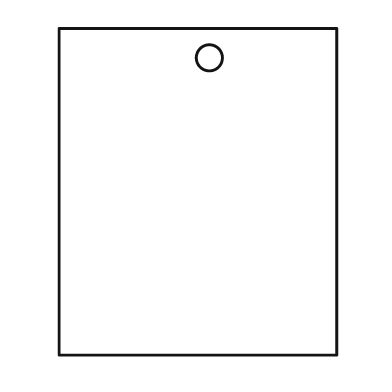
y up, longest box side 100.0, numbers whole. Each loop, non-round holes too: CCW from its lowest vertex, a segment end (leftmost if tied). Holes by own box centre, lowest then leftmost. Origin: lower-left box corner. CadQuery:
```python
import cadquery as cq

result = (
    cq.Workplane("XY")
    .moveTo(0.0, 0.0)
    .lineTo(85.0, 0.0)
    .lineTo(85.0, 100.0)
    .lineTo(0.0, 100.0)
    .close()
    .moveTo(46.0, 91.0)
    .circle(4.0)
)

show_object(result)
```